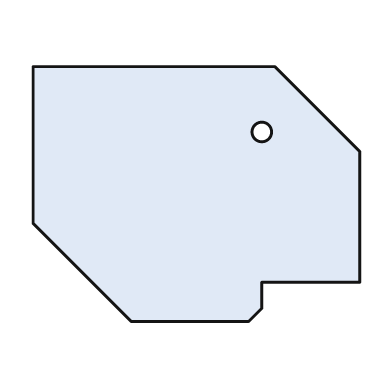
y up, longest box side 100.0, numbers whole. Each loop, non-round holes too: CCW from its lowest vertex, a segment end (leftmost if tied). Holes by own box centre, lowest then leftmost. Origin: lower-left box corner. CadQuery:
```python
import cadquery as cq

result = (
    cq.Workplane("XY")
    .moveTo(30.0, 0.0)
    .lineTo(66.0, 0.0)
    .lineTo(70.0, 4.0)
    .lineTo(70.0, 12.0)
    .lineTo(100.0, 12.0)
    .lineTo(100.0, 52.0)
    .lineTo(74.0, 78.0)
    .lineTo(0.0, 78.0)
    .lineTo(0.0, 30.0)
    .close()
    .moveTo(70.0, 58.0)
    .circle(3.0)
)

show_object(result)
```